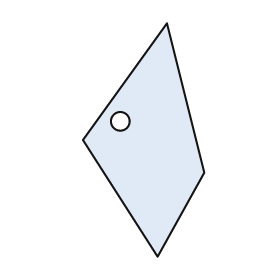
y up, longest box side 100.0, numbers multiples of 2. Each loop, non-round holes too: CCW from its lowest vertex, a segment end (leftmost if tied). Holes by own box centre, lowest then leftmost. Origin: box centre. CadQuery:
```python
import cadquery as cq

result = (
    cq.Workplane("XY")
    .moveTo(6.0, -50.0)
    .lineTo(26.0, -14.0)
    .lineTo(10.0, 50.0)
    .lineTo(-26.0, 0.0)
    .close()
    .moveTo(-10.0, 8.0)
    .circle(4.0)
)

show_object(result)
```